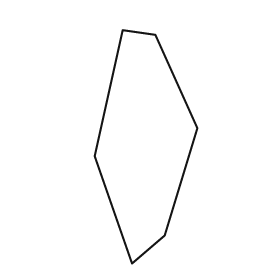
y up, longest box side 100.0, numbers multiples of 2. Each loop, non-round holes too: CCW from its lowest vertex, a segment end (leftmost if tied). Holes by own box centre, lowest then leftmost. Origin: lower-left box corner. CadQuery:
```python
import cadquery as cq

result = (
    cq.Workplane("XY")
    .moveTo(16.0, 0.0)
    .lineTo(30.0, 12.0)
    .lineTo(44.0, 58.0)
    .lineTo(26.0, 98.0)
    .lineTo(12.0, 100.0)
    .lineTo(0.0, 46.0)
    .close()
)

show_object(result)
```